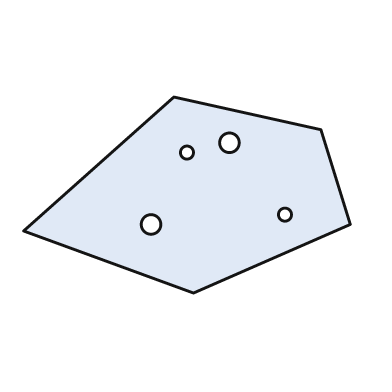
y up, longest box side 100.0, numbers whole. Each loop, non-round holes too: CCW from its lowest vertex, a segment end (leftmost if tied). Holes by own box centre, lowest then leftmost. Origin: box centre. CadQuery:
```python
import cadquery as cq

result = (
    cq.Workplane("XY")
    .moveTo(2.0, -30.0)
    .lineTo(50.0, -9.0)
    .lineTo(41.0, 20.0)
    .lineTo(-4.0, 30.0)
    .lineTo(-50.0, -11.0)
    .close()
    .moveTo(-11.0, -9.0)
    .circle(3.0)
    .moveTo(30.0, -6.0)
    .circle(2.0)
    .moveTo(0.0, 13.0)
    .circle(2.0)
    .moveTo(13.0, 16.0)
    .circle(3.0)
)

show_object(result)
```